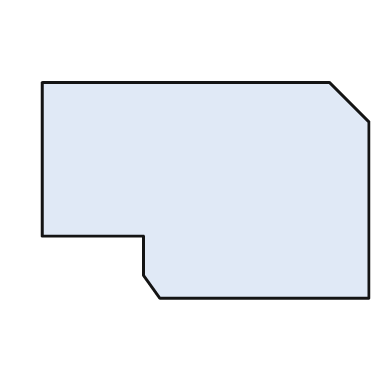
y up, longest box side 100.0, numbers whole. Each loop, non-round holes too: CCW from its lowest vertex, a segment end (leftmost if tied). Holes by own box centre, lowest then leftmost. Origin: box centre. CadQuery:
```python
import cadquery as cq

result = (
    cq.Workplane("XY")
    .moveTo(-14.0, -33.0)
    .lineTo(50.0, -33.0)
    .lineTo(50.0, 21.0)
    .lineTo(38.0, 33.0)
    .lineTo(-50.0, 33.0)
    .lineTo(-50.0, -14.0)
    .lineTo(-19.0, -14.0)
    .lineTo(-19.0, -26.0)
    .close()
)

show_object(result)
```